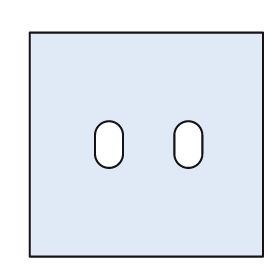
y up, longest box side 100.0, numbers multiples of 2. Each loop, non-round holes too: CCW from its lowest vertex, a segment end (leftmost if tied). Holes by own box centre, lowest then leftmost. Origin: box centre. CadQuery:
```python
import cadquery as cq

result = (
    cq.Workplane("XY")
    .moveTo(-50.0, -48.0)
    .lineTo(50.0, -48.0)
    .lineTo(50.0, 48.0)
    .lineTo(-50.0, 48.0)
    .close()
    .moveTo(-22.0, -4.0)
    .threePointArc((-16.0, -10.0), (-10.0, -4.0))
    .lineTo(-10.0, 4.0)
    .threePointArc((-16.0, 10.0), (-22.0, 4.0))
    .close()
    .moveTo(12.0, -4.0)
    .threePointArc((18.0, -10.0), (24.0, -4.0))
    .lineTo(24.0, 4.0)
    .threePointArc((18.0, 10.0), (12.0, 4.0))
    .close()
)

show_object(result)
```